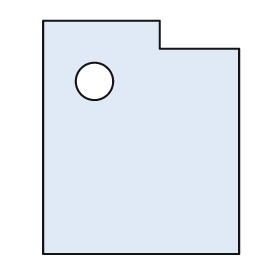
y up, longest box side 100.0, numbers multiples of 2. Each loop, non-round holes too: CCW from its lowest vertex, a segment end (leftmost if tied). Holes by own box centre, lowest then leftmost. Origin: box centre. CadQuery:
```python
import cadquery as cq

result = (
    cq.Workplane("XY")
    .moveTo(-42.0, -50.0)
    .lineTo(42.0, -50.0)
    .lineTo(42.0, 38.0)
    .lineTo(8.0, 38.0)
    .lineTo(8.0, 50.0)
    .lineTo(-42.0, 50.0)
    .close()
    .moveTo(-20.0, 24.0)
    .circle(8.0)
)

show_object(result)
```